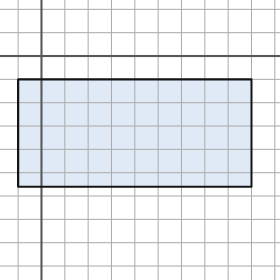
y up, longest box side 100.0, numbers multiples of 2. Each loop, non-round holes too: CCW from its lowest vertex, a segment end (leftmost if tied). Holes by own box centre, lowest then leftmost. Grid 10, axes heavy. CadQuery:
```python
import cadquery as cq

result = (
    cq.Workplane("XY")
    .moveTo(-10.0, -56.0)
    .lineTo(90.0, -56.0)
    .lineTo(90.0, -10.0)
    .lineTo(-10.0, -10.0)
    .close()
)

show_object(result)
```